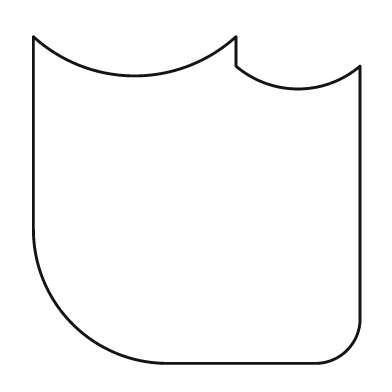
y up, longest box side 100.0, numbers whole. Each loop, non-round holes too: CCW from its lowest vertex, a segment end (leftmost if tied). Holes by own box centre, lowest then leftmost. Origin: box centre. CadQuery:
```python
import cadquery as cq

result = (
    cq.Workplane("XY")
    .moveTo(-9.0, -50.0)
    .lineTo(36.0, -50.0)
    .threePointArc((46.0, -46.0), (50.0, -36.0))
    .lineTo(50.0, 41.0)
    .threePointArc((31.0, 34.0), (12.0, 41.0))
    .lineTo(12.0, 50.0)
    .threePointArc((-19.0, 38.0), (-50.0, 50.0))
    .lineTo(-50.0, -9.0)
    .threePointArc((-38.0, -38.0), (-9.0, -50.0))
    .close()
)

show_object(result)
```